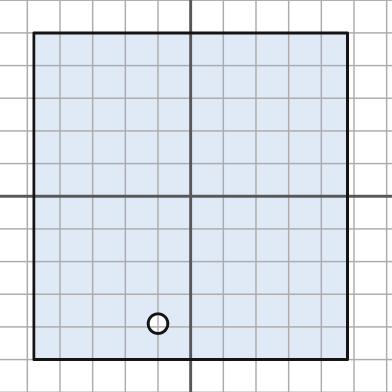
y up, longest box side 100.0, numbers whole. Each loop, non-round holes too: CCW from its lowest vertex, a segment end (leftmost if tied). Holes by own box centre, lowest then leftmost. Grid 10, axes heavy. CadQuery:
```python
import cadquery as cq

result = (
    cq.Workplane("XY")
    .moveTo(-48.0, -50.0)
    .lineTo(48.0, -50.0)
    .lineTo(48.0, 50.0)
    .lineTo(-48.0, 50.0)
    .close()
    .moveTo(-10.0, -39.0)
    .circle(3.0)
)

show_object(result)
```